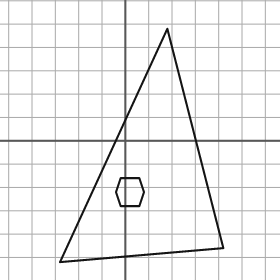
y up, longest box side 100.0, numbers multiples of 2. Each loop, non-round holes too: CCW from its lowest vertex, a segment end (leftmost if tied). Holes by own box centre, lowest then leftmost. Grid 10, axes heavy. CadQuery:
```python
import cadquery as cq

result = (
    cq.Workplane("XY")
    .moveTo(-28.0, -52.0)
    .lineTo(42.0, -46.0)
    .lineTo(18.0, 48.0)
    .close()
    .moveTo(-2.0, -28.0)
    .lineTo(6.0, -28.0)
    .lineTo(8.0, -22.0)
    .lineTo(6.0, -16.0)
    .lineTo(-2.0, -16.0)
    .lineTo(-4.0, -22.0)
    .close()
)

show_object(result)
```